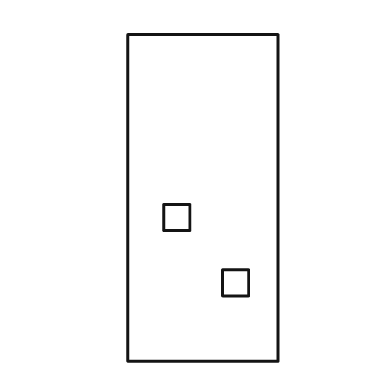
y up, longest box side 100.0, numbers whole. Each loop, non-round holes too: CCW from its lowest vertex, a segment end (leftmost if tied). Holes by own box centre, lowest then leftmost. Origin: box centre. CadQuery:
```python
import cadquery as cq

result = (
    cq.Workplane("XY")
    .moveTo(-23.0, -50.0)
    .lineTo(23.0, -50.0)
    .lineTo(23.0, 50.0)
    .lineTo(-23.0, 50.0)
    .close()
    .moveTo(6.0, -30.0)
    .lineTo(14.0, -30.0)
    .lineTo(14.0, -22.0)
    .lineTo(6.0, -22.0)
    .close()
    .moveTo(-12.0, -10.0)
    .lineTo(-4.0, -10.0)
    .lineTo(-4.0, -2.0)
    .lineTo(-12.0, -2.0)
    .close()
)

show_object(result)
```